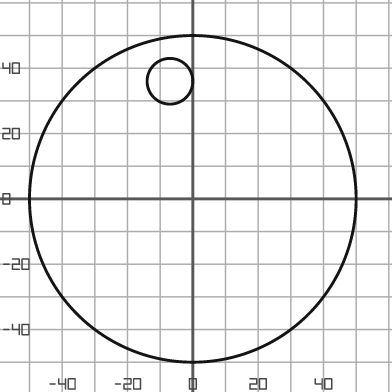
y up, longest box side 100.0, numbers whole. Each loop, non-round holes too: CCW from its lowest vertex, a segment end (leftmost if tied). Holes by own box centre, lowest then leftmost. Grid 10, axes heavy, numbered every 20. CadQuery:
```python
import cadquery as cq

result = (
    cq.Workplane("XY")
    .moveTo(0.0, 0.0)
    .circle(50.0)
    .moveTo(-7.0, 36.0)
    .circle(7.0)
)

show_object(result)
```